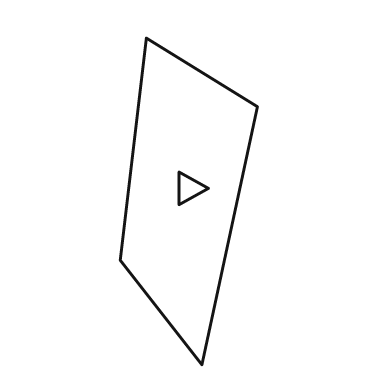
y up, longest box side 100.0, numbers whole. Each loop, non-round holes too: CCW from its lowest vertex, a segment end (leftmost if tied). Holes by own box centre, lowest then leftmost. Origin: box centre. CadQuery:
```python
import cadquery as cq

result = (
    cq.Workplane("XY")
    .moveTo(4.0, -50.0)
    .lineTo(21.0, 29.0)
    .lineTo(-13.0, 50.0)
    .lineTo(-21.0, -18.0)
    .close()
    .moveTo(-3.0, -1.0)
    .lineTo(6.0, 4.0)
    .lineTo(-3.0, 9.0)
    .close()
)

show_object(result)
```